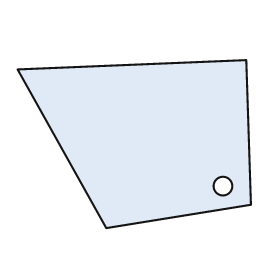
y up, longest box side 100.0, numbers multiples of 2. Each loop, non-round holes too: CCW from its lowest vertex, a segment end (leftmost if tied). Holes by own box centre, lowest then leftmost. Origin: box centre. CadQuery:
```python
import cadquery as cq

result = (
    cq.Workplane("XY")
    .moveTo(-12.0, -36.0)
    .lineTo(50.0, -26.0)
    .lineTo(48.0, 36.0)
    .lineTo(-50.0, 32.0)
    .close()
    .moveTo(38.0, -18.0)
    .circle(4.0)
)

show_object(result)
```